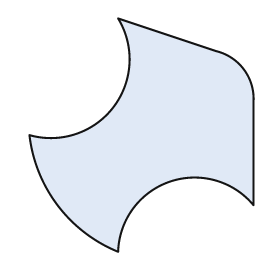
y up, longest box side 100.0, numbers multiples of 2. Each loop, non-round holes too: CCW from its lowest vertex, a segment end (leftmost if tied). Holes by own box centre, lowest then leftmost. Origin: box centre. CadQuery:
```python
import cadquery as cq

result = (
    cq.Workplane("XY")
    .moveTo(-10.0, -50.0)
    .threePointArc((12.0, -20.0), (48.0, -30.0))
    .lineTo(48.0, 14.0)
    .threePointArc((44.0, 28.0), (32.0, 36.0))
    .lineTo(-10.0, 50.0)
    .threePointArc((-12.0, 12.0), (-48.0, 0.0))
    .threePointArc((-36.0, -30.0), (-10.0, -50.0))
    .close()
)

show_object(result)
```